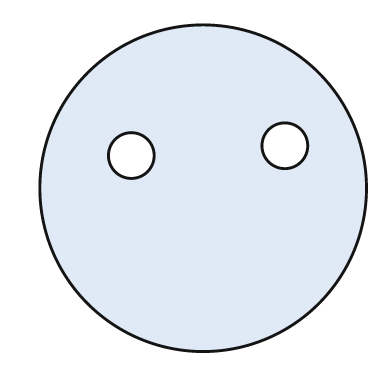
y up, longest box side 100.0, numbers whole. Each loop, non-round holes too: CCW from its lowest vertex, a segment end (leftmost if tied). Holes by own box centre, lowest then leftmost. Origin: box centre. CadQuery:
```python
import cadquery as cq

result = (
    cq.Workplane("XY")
    .moveTo(0.0, 0.0)
    .circle(50.0)
    .moveTo(-22.0, 10.0)
    .circle(7.0)
    .moveTo(25.0, 13.0)
    .circle(7.0)
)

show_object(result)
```